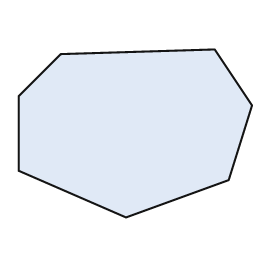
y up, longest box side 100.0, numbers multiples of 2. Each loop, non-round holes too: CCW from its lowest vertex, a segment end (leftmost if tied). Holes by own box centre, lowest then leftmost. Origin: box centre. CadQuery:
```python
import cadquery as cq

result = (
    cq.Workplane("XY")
    .moveTo(-4.0, -36.0)
    .lineTo(40.0, -20.0)
    .lineTo(50.0, 12.0)
    .lineTo(34.0, 36.0)
    .lineTo(-32.0, 34.0)
    .lineTo(-50.0, 16.0)
    .lineTo(-50.0, -16.0)
    .close()
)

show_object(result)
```